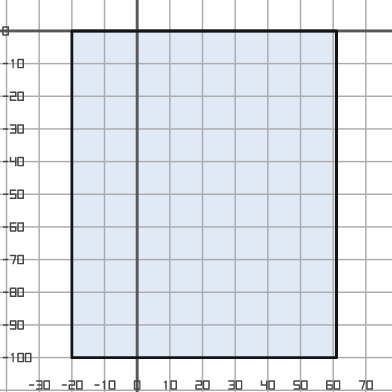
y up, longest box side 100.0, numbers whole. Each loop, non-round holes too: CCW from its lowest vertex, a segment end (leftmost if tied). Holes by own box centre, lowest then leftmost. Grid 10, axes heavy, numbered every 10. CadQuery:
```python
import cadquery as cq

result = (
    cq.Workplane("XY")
    .moveTo(-20.0, -100.0)
    .lineTo(61.0, -100.0)
    .lineTo(61.0, 0.0)
    .lineTo(-20.0, 0.0)
    .close()
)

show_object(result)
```